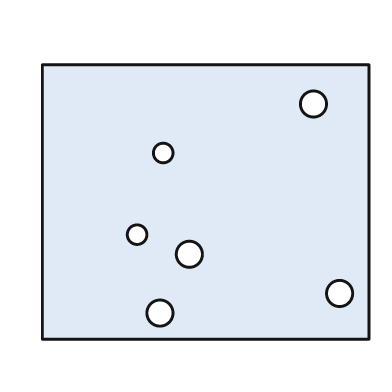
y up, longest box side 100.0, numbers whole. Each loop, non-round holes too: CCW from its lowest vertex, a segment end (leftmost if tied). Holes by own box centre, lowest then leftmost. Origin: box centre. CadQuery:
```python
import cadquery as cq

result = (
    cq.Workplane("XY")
    .moveTo(-50.0, -42.0)
    .lineTo(50.0, -42.0)
    .lineTo(50.0, 42.0)
    .lineTo(-50.0, 42.0)
    .close()
    .moveTo(-14.0, -34.0)
    .circle(4.0)
    .moveTo(41.0, -28.0)
    .circle(4.0)
    .moveTo(-5.0, -16.0)
    .circle(4.0)
    .moveTo(-21.0, -10.0)
    .circle(3.0)
    .moveTo(-13.0, 15.0)
    .circle(3.0)
    .moveTo(33.0, 30.0)
    .circle(4.0)
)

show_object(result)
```